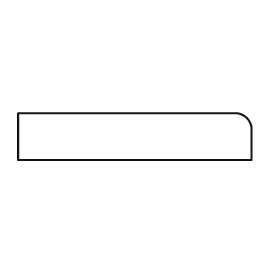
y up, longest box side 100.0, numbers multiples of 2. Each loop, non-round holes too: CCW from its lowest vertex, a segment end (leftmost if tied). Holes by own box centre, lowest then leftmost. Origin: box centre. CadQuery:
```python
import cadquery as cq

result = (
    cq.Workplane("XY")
    .moveTo(-50.0, -10.0)
    .lineTo(50.0, -10.0)
    .lineTo(50.0, 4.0)
    .threePointArc((48.0, 8.0), (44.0, 10.0))
    .lineTo(-50.0, 10.0)
    .close()
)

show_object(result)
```